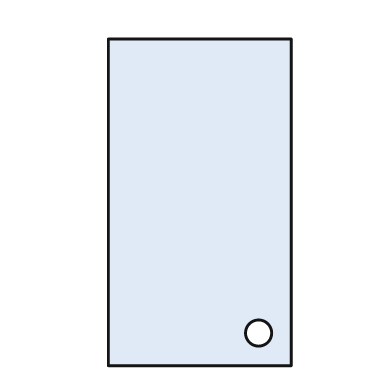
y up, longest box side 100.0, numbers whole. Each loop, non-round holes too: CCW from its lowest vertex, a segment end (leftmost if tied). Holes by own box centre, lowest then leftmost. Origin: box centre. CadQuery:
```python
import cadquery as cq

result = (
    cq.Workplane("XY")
    .moveTo(-28.0, -50.0)
    .lineTo(28.0, -50.0)
    .lineTo(28.0, 50.0)
    .lineTo(-28.0, 50.0)
    .close()
    .moveTo(18.0, -40.0)
    .circle(4.0)
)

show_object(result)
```